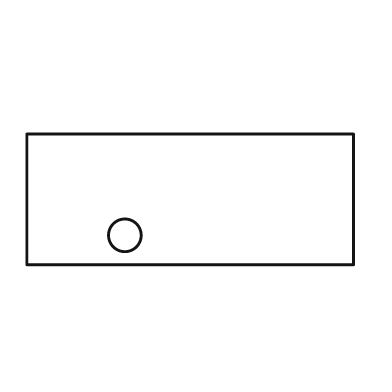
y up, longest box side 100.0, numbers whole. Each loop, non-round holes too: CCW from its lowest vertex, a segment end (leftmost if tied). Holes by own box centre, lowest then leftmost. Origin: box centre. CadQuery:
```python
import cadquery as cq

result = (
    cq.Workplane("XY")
    .moveTo(-50.0, -20.0)
    .lineTo(50.0, -20.0)
    .lineTo(50.0, 20.0)
    .lineTo(-50.0, 20.0)
    .close()
    .moveTo(-20.0, -11.0)
    .circle(5.0)
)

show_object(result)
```